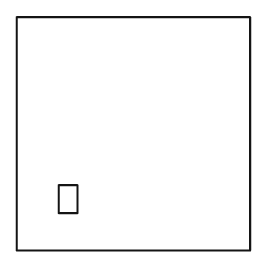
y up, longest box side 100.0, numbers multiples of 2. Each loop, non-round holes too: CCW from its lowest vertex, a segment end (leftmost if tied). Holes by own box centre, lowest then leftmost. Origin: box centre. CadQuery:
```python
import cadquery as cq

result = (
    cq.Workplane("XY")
    .moveTo(-50.0, -50.0)
    .lineTo(50.0, -50.0)
    .lineTo(50.0, 50.0)
    .lineTo(-50.0, 50.0)
    .close()
    .moveTo(-32.0, -34.0)
    .lineTo(-24.0, -34.0)
    .lineTo(-24.0, -22.0)
    .lineTo(-32.0, -22.0)
    .close()
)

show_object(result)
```